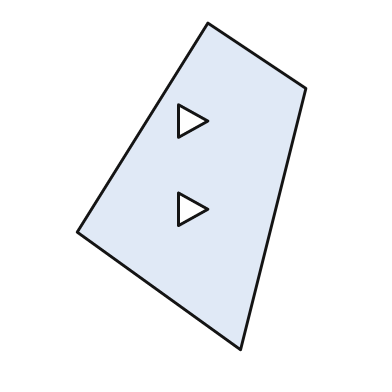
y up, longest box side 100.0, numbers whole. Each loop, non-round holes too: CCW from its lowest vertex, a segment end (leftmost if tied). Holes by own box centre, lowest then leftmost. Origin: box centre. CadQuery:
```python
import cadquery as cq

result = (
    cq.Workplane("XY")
    .moveTo(15.0, -50.0)
    .lineTo(35.0, 30.0)
    .lineTo(5.0, 50.0)
    .lineTo(-35.0, -14.0)
    .close()
    .moveTo(-4.0, -12.0)
    .lineTo(5.0, -7.0)
    .lineTo(-4.0, -2.0)
    .close()
    .moveTo(-4.0, 15.0)
    .lineTo(5.0, 20.0)
    .lineTo(-4.0, 25.0)
    .close()
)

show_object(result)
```